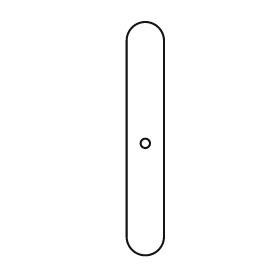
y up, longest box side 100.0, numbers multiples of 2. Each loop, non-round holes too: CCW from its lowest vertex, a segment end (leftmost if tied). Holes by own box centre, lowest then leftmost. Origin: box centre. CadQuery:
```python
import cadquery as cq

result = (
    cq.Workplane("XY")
    .moveTo(-8.0, -42.0)
    .threePointArc((0.0, -50.0), (8.0, -42.0))
    .lineTo(8.0, 42.0)
    .threePointArc((0.0, 50.0), (-8.0, 42.0))
    .close()
    .moveTo(0.0, -2.0)
    .circle(2.0)
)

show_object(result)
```